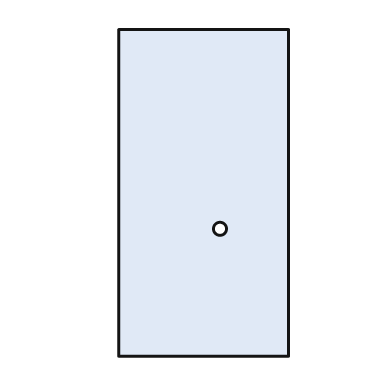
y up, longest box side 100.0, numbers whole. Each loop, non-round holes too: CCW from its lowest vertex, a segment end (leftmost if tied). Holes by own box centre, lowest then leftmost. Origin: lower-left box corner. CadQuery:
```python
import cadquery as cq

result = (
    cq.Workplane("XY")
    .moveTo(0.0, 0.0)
    .lineTo(52.0, 0.0)
    .lineTo(52.0, 100.0)
    .lineTo(0.0, 100.0)
    .close()
    .moveTo(31.0, 39.0)
    .circle(2.0)
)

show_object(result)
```